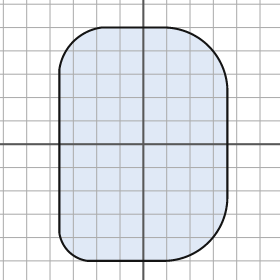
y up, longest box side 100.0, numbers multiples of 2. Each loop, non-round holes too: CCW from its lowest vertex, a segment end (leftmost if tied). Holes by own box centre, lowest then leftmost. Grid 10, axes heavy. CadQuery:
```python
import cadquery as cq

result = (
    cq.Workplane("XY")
    .moveTo(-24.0, -50.0)
    .lineTo(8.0, -50.0)
    .threePointArc((28.0, -42.0), (36.0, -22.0))
    .lineTo(36.0, 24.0)
    .threePointArc((28.0, 42.0), (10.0, 50.0))
    .lineTo(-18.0, 50.0)
    .threePointArc((-30.0, 44.0), (-36.0, 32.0))
    .lineTo(-36.0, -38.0)
    .threePointArc((-32.0, -46.0), (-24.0, -50.0))
    .close()
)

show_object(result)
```